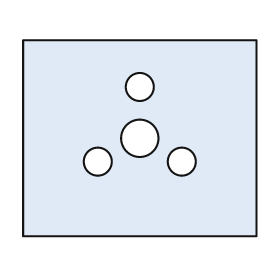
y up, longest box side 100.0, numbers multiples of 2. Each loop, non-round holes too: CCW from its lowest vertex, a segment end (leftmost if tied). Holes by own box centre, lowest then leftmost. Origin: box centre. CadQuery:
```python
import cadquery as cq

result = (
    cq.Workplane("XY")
    .moveTo(-50.0, -42.0)
    .lineTo(50.0, -42.0)
    .lineTo(50.0, 42.0)
    .lineTo(-50.0, 42.0)
    .close()
    .moveTo(-18.0, -10.0)
    .circle(6.0)
    .moveTo(18.0, -10.0)
    .circle(6.0)
    .moveTo(0.0, 0.0)
    .circle(8.0)
    .moveTo(0.0, 22.0)
    .circle(6.0)
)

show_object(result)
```